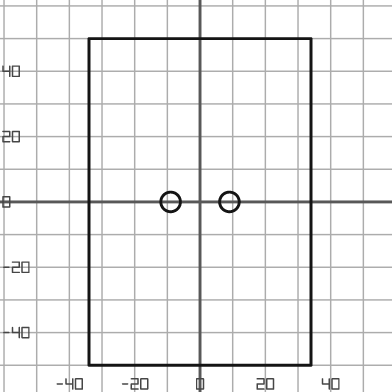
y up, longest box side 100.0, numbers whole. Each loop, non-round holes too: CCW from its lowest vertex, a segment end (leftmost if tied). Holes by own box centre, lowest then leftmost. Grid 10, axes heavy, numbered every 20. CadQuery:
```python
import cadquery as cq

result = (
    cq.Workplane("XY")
    .moveTo(-34.0, -50.0)
    .lineTo(34.0, -50.0)
    .lineTo(34.0, 50.0)
    .lineTo(-34.0, 50.0)
    .close()
    .moveTo(-9.0, 0.0)
    .circle(3.0)
    .moveTo(9.0, 0.0)
    .circle(3.0)
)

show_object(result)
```